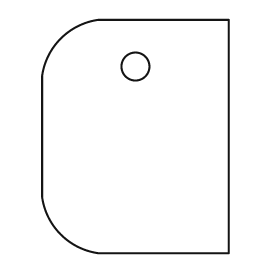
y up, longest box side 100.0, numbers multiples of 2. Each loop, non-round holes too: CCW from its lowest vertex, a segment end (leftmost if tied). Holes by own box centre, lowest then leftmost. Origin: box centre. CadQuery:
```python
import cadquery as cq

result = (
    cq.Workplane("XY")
    .moveTo(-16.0, -50.0)
    .lineTo(40.0, -50.0)
    .lineTo(40.0, 50.0)
    .lineTo(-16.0, 50.0)
    .threePointArc((-32.0, 42.0), (-40.0, 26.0))
    .lineTo(-40.0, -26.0)
    .threePointArc((-32.0, -42.0), (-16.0, -50.0))
    .close()
    .moveTo(0.0, 30.0)
    .circle(6.0)
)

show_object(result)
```